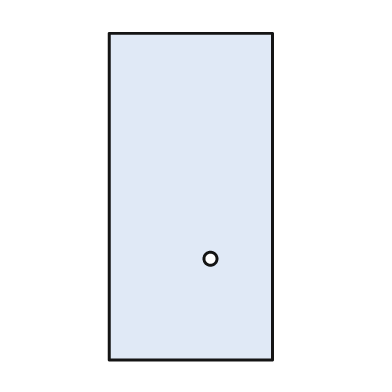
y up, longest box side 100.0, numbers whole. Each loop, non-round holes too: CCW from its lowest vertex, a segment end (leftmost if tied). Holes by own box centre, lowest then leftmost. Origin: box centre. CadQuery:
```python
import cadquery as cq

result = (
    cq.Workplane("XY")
    .moveTo(-25.0, -50.0)
    .lineTo(25.0, -50.0)
    .lineTo(25.0, 50.0)
    .lineTo(-25.0, 50.0)
    .close()
    .moveTo(6.0, -19.0)
    .circle(2.0)
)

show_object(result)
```